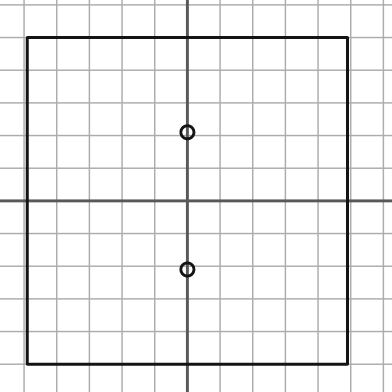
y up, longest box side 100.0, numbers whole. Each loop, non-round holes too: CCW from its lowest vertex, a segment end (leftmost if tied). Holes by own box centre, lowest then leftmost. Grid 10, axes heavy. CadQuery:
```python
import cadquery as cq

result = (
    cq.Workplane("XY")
    .moveTo(-49.0, -50.0)
    .lineTo(49.0, -50.0)
    .lineTo(49.0, 50.0)
    .lineTo(-49.0, 50.0)
    .close()
    .moveTo(0.0, -21.0)
    .circle(2.0)
    .moveTo(0.0, 21.0)
    .circle(2.0)
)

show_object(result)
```